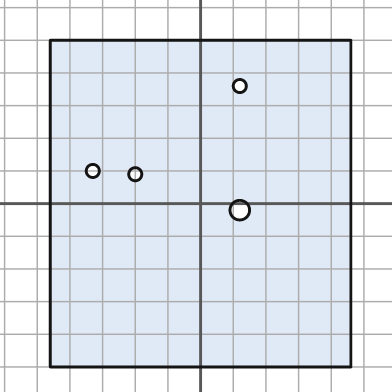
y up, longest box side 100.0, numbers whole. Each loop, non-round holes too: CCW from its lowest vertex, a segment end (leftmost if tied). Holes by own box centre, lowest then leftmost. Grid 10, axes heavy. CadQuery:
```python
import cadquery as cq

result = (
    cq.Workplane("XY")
    .moveTo(-46.0, -50.0)
    .lineTo(46.0, -50.0)
    .lineTo(46.0, 50.0)
    .lineTo(-46.0, 50.0)
    .close()
    .moveTo(12.0, -2.0)
    .circle(3.0)
    .moveTo(-20.0, 9.0)
    .circle(2.0)
    .moveTo(-33.0, 10.0)
    .circle(2.0)
    .moveTo(12.0, 36.0)
    .circle(2.0)
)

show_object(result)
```